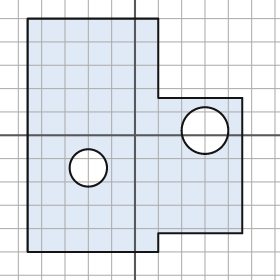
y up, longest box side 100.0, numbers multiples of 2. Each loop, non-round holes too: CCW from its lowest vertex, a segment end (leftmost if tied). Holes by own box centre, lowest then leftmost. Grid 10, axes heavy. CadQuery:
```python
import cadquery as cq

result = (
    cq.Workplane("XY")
    .moveTo(-46.0, -50.0)
    .lineTo(10.0, -50.0)
    .lineTo(10.0, -42.0)
    .lineTo(46.0, -42.0)
    .lineTo(46.0, 16.0)
    .lineTo(10.0, 16.0)
    .lineTo(10.0, 50.0)
    .lineTo(-46.0, 50.0)
    .close()
    .moveTo(-20.0, -14.0)
    .circle(8.0)
    .moveTo(30.0, 2.0)
    .circle(10.0)
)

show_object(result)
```